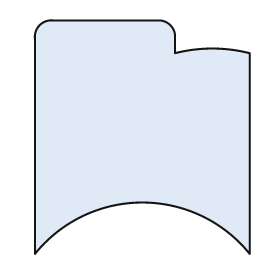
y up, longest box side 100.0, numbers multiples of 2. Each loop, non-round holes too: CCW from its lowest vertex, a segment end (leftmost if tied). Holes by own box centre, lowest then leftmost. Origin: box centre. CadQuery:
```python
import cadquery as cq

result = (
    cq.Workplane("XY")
    .moveTo(-46.0, -50.0)
    .threePointArc((0.0, -28.0), (46.0, -50.0))
    .lineTo(46.0, 36.0)
    .threePointArc((30.0, 38.0), (14.0, 36.0))
    .lineTo(14.0, 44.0)
    .threePointArc((12.0, 48.0), (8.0, 50.0))
    .lineTo(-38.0, 50.0)
    .threePointArc((-44.0, 48.0), (-46.0, 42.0))
    .close()
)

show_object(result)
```